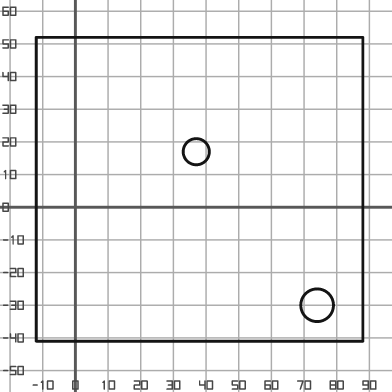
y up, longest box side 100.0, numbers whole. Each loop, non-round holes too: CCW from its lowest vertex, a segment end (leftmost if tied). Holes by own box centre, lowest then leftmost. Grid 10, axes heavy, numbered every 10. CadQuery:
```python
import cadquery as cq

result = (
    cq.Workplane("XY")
    .moveTo(-12.0, -41.0)
    .lineTo(88.0, -41.0)
    .lineTo(88.0, 52.0)
    .lineTo(-12.0, 52.0)
    .close()
    .moveTo(74.0, -30.0)
    .circle(5.0)
    .moveTo(37.0, 17.0)
    .circle(4.0)
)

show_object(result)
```